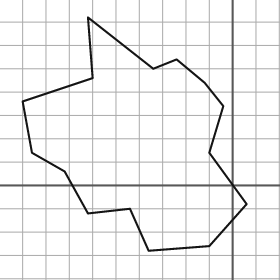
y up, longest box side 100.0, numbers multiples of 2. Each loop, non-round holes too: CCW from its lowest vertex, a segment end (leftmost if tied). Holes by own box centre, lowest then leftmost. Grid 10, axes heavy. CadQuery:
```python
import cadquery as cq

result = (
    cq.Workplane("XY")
    .moveTo(-36.0, -28.0)
    .lineTo(-10.0, -26.0)
    .lineTo(6.0, -8.0)
    .lineTo(-10.0, 14.0)
    .lineTo(-4.0, 34.0)
    .lineTo(-12.0, 44.0)
    .lineTo(-24.0, 54.0)
    .lineTo(-34.0, 50.0)
    .lineTo(-62.0, 72.0)
    .lineTo(-60.0, 46.0)
    .lineTo(-90.0, 36.0)
    .lineTo(-86.0, 14.0)
    .lineTo(-72.0, 6.0)
    .lineTo(-62.0, -12.0)
    .lineTo(-44.0, -10.0)
    .close()
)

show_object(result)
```